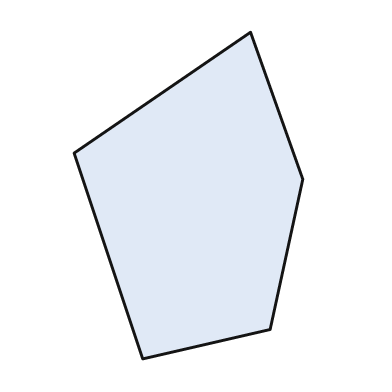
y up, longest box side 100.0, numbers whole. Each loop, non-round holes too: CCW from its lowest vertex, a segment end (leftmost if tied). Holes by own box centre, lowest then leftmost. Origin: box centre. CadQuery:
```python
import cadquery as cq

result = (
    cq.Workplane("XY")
    .moveTo(-14.0, -50.0)
    .lineTo(25.0, -41.0)
    .lineTo(35.0, 5.0)
    .lineTo(19.0, 50.0)
    .lineTo(-35.0, 13.0)
    .close()
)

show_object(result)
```